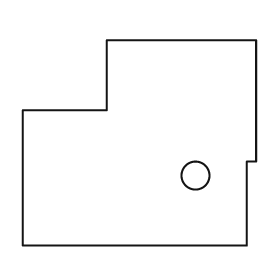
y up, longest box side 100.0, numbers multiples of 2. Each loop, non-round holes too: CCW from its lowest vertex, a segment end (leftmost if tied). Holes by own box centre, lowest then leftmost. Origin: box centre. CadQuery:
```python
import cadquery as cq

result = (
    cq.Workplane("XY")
    .moveTo(-50.0, -44.0)
    .lineTo(46.0, -44.0)
    .lineTo(46.0, -8.0)
    .lineTo(50.0, -8.0)
    .lineTo(50.0, 44.0)
    .lineTo(-14.0, 44.0)
    .lineTo(-14.0, 14.0)
    .lineTo(-50.0, 14.0)
    .close()
    .moveTo(24.0, -14.0)
    .circle(6.0)
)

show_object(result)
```